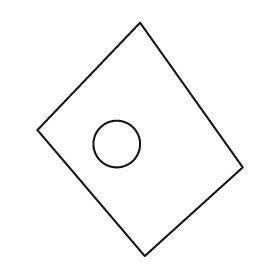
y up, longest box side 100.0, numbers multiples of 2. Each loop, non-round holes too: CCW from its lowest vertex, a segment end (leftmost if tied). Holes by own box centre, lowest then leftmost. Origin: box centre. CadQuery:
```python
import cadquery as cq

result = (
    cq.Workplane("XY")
    .moveTo(2.0, -50.0)
    .lineTo(44.0, -12.0)
    .lineTo(0.0, 50.0)
    .lineTo(-44.0, 4.0)
    .close()
    .moveTo(-10.0, -2.0)
    .circle(10.0)
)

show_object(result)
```